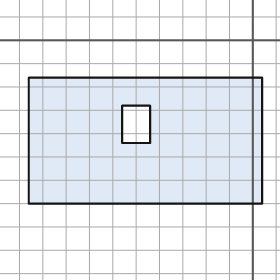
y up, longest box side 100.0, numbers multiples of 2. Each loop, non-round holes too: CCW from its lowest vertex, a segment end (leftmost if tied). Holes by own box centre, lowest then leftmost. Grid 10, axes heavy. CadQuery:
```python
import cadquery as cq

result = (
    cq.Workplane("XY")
    .moveTo(-96.0, -70.0)
    .lineTo(4.0, -70.0)
    .lineTo(4.0, -16.0)
    .lineTo(-96.0, -16.0)
    .close()
    .moveTo(-56.0, -44.0)
    .lineTo(-44.0, -44.0)
    .lineTo(-44.0, -28.0)
    .lineTo(-56.0, -28.0)
    .close()
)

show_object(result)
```